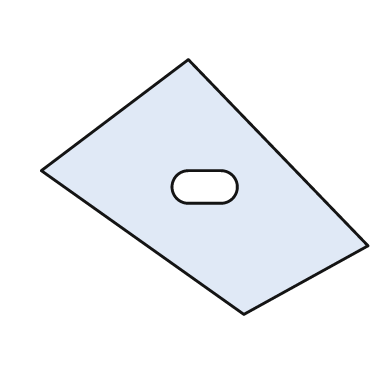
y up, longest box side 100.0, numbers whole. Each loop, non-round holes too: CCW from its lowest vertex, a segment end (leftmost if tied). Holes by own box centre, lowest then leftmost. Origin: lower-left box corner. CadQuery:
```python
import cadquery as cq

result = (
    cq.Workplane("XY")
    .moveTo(62.0, 0.0)
    .lineTo(100.0, 21.0)
    .lineTo(45.0, 78.0)
    .lineTo(0.0, 44.0)
    .close()
    .moveTo(45.0, 34.0)
    .lineTo(55.0, 34.0)
    .threePointArc((60.0, 39.0), (55.0, 44.0))
    .lineTo(45.0, 44.0)
    .threePointArc((40.0, 39.0), (45.0, 34.0))
    .close()
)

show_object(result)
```